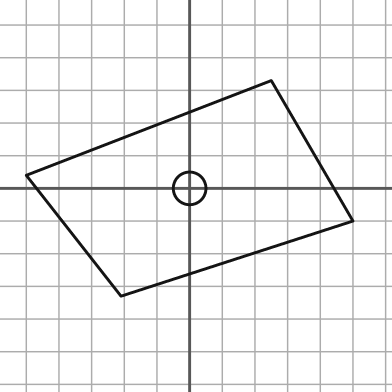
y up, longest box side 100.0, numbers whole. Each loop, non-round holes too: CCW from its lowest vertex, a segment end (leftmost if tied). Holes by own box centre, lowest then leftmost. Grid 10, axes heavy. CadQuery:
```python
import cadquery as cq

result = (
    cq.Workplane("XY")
    .moveTo(-21.0, -33.0)
    .lineTo(50.0, -10.0)
    .lineTo(25.0, 33.0)
    .lineTo(-50.0, 4.0)
    .close()
    .moveTo(0.0, 0.0)
    .circle(5.0)
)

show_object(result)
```